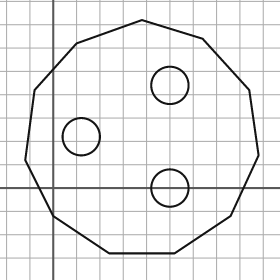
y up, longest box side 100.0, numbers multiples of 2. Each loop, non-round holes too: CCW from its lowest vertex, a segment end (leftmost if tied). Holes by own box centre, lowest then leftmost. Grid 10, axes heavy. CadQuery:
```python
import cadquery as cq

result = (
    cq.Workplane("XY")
    .moveTo(24.0, -28.0)
    .lineTo(52.0, -28.0)
    .lineTo(76.0, -12.0)
    .lineTo(88.0, 14.0)
    .lineTo(84.0, 42.0)
    .lineTo(64.0, 64.0)
    .lineTo(38.0, 72.0)
    .lineTo(10.0, 62.0)
    .lineTo(-8.0, 42.0)
    .lineTo(-12.0, 12.0)
    .lineTo(0.0, -12.0)
    .close()
    .moveTo(50.0, 0.0)
    .circle(8.0)
    .moveTo(12.0, 22.0)
    .circle(8.0)
    .moveTo(50.0, 44.0)
    .circle(8.0)
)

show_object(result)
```